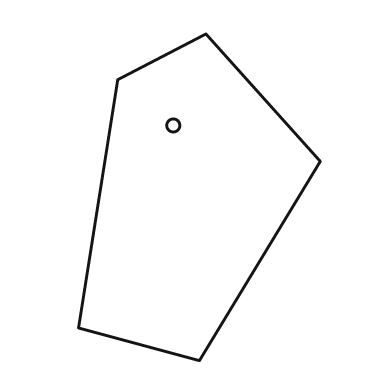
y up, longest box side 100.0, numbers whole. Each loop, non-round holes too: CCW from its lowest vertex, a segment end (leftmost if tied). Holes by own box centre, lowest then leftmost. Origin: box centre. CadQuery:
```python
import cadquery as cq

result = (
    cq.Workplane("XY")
    .moveTo(0.0, -50.0)
    .lineTo(37.0, 11.0)
    .lineTo(2.0, 50.0)
    .lineTo(-25.0, 36.0)
    .lineTo(-37.0, -40.0)
    .close()
    .moveTo(-8.0, 22.0)
    .circle(2.0)
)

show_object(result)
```